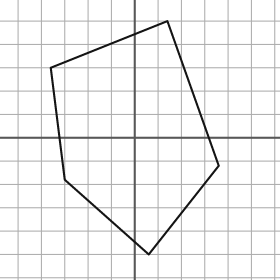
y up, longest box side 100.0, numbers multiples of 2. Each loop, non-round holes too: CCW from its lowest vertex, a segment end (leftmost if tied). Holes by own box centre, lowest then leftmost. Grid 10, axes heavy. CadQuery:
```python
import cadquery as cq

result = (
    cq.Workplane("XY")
    .moveTo(6.0, -50.0)
    .lineTo(36.0, -12.0)
    .lineTo(14.0, 50.0)
    .lineTo(-36.0, 30.0)
    .lineTo(-30.0, -18.0)
    .close()
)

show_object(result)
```